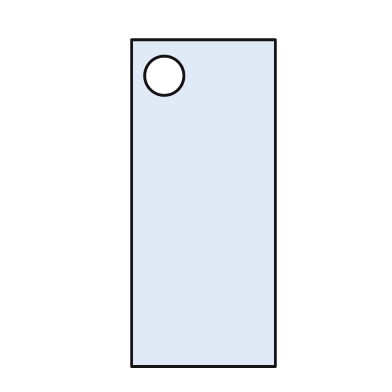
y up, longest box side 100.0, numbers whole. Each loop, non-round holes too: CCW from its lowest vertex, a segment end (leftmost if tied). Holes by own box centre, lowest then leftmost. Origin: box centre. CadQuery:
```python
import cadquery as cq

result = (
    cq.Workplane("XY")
    .moveTo(-22.0, -50.0)
    .lineTo(22.0, -50.0)
    .lineTo(22.0, 50.0)
    .lineTo(-22.0, 50.0)
    .close()
    .moveTo(-12.0, 39.0)
    .circle(6.0)
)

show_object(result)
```